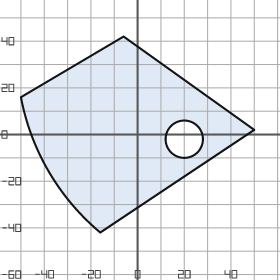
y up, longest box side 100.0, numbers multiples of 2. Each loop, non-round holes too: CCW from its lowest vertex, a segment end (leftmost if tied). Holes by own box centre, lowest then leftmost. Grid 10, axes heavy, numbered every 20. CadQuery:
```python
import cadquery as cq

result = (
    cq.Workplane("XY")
    .moveTo(-16.0, -42.0)
    .lineTo(50.0, 2.0)
    .lineTo(-6.0, 42.0)
    .lineTo(-50.0, 16.0)
    .threePointArc((-38.0, -16.0), (-16.0, -42.0))
    .close()
    .moveTo(20.0, -2.0)
    .circle(8.0)
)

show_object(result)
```